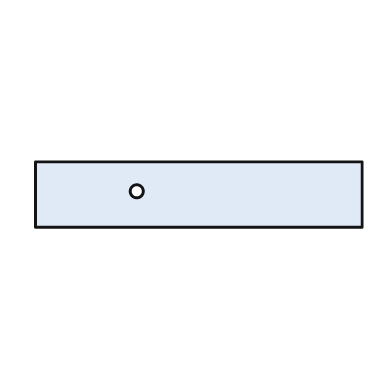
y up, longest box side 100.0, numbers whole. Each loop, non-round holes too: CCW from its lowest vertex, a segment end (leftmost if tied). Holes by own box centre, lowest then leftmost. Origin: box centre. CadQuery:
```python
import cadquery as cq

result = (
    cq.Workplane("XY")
    .moveTo(-50.0, -10.0)
    .lineTo(50.0, -10.0)
    .lineTo(50.0, 10.0)
    .lineTo(-50.0, 10.0)
    .close()
    .moveTo(-19.0, 1.0)
    .circle(2.0)
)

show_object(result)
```